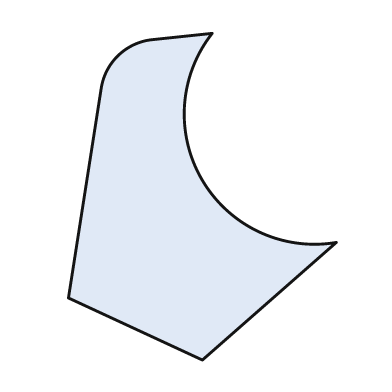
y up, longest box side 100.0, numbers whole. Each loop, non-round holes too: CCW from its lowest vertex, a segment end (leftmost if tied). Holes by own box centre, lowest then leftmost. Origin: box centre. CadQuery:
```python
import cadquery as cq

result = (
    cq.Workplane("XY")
    .moveTo(0.0, -50.0)
    .lineTo(41.0, -14.0)
    .threePointArc((0.0, 5.0), (3.0, 50.0))
    .lineTo(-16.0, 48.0)
    .threePointArc((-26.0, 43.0), (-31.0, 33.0))
    .lineTo(-41.0, -31.0)
    .close()
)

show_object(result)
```